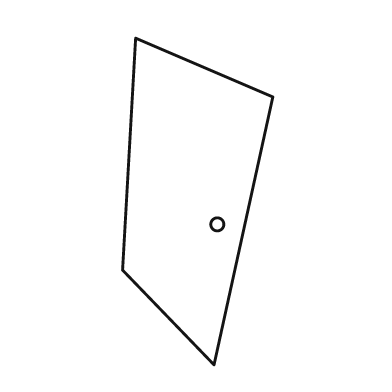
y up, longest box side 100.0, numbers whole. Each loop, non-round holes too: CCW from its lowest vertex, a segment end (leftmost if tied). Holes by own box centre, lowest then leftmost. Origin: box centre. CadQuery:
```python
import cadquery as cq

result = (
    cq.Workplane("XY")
    .moveTo(5.0, -50.0)
    .lineTo(23.0, 32.0)
    .lineTo(-19.0, 50.0)
    .lineTo(-23.0, -21.0)
    .close()
    .moveTo(6.0, -7.0)
    .circle(2.0)
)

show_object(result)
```